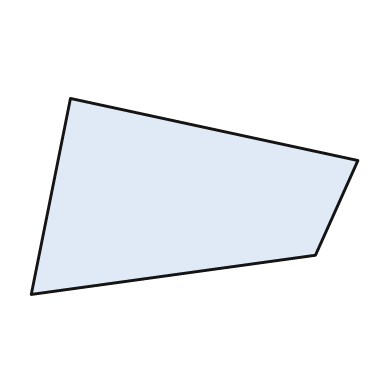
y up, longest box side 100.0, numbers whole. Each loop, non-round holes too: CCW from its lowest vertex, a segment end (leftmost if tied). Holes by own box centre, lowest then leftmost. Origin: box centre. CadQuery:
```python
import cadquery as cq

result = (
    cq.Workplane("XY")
    .moveTo(-50.0, -30.0)
    .lineTo(37.0, -18.0)
    .lineTo(50.0, 11.0)
    .lineTo(-38.0, 30.0)
    .close()
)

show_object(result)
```